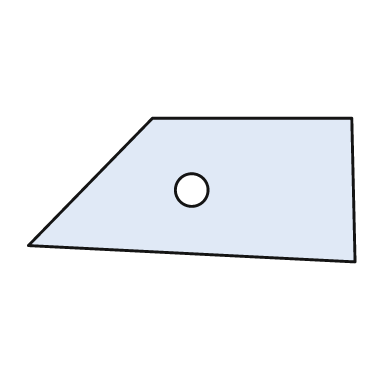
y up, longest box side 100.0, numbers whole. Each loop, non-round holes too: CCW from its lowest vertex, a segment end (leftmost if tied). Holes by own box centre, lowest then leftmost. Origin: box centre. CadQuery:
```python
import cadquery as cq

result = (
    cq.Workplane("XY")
    .moveTo(50.0, -22.0)
    .lineTo(49.0, 22.0)
    .lineTo(-12.0, 22.0)
    .lineTo(-50.0, -17.0)
    .close()
    .moveTo(0.0, 0.0)
    .circle(5.0)
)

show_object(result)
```